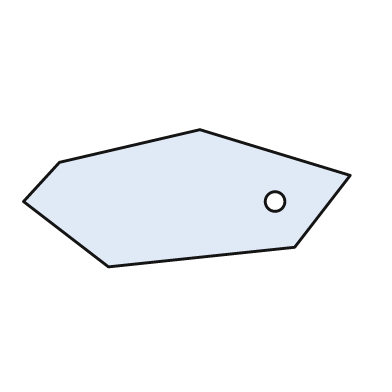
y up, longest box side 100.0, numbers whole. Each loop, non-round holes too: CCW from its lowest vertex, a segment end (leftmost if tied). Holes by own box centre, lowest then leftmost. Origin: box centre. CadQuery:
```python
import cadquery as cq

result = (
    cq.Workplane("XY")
    .moveTo(-24.0, -21.0)
    .lineTo(33.0, -15.0)
    .lineTo(50.0, 7.0)
    .lineTo(4.0, 21.0)
    .lineTo(-39.0, 11.0)
    .lineTo(-50.0, -1.0)
    .close()
    .moveTo(27.0, -1.0)
    .circle(3.0)
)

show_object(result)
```